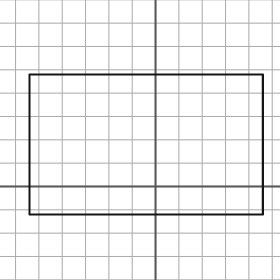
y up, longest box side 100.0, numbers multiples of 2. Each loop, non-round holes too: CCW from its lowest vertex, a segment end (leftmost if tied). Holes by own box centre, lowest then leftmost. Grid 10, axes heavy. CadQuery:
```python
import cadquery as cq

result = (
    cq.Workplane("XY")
    .moveTo(-54.0, -12.0)
    .lineTo(46.0, -12.0)
    .lineTo(46.0, 48.0)
    .lineTo(-54.0, 48.0)
    .close()
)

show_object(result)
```